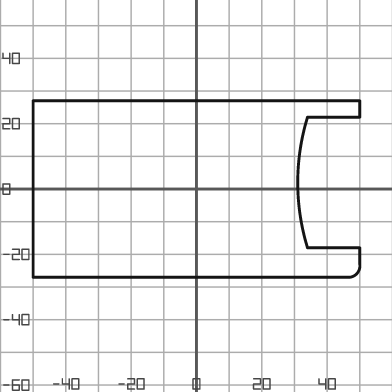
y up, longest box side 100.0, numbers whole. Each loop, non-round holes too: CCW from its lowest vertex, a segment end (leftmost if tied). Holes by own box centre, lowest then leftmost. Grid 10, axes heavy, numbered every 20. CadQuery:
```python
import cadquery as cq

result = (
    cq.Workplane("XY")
    .moveTo(-50.0, -27.0)
    .lineTo(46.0, -27.0)
    .threePointArc((49.0, -26.0), (50.0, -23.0))
    .lineTo(50.0, -18.0)
    .lineTo(34.0, -18.0)
    .threePointArc((31.0, 2.0), (34.0, 22.0))
    .lineTo(50.0, 22.0)
    .lineTo(50.0, 27.0)
    .lineTo(-50.0, 27.0)
    .close()
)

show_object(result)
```